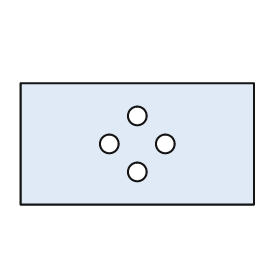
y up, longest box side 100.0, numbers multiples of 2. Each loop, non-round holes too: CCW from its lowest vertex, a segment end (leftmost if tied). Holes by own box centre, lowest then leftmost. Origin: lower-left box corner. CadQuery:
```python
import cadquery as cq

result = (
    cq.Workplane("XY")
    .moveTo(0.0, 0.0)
    .lineTo(100.0, 0.0)
    .lineTo(100.0, 52.0)
    .lineTo(0.0, 52.0)
    .close()
    .moveTo(50.0, 14.0)
    .circle(4.0)
    .moveTo(38.0, 26.0)
    .circle(4.0)
    .moveTo(62.0, 26.0)
    .circle(4.0)
    .moveTo(50.0, 38.0)
    .circle(4.0)
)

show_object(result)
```